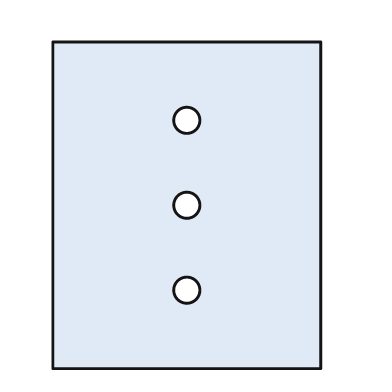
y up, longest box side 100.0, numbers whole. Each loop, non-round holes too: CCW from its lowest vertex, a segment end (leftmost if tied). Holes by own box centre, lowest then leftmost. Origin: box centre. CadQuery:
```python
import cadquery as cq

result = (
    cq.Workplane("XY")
    .moveTo(-41.0, -50.0)
    .lineTo(41.0, -50.0)
    .lineTo(41.0, 50.0)
    .lineTo(-41.0, 50.0)
    .close()
    .moveTo(0.0, -26.0)
    .circle(4.0)
    .moveTo(0.0, 0.0)
    .circle(4.0)
    .moveTo(0.0, 26.0)
    .circle(4.0)
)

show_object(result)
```